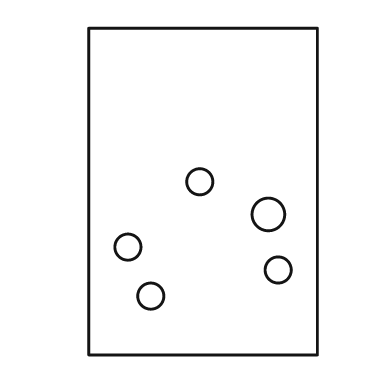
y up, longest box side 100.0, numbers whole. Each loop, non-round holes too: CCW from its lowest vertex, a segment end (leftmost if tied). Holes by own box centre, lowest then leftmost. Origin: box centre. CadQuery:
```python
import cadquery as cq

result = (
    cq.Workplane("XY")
    .moveTo(-35.0, -50.0)
    .lineTo(35.0, -50.0)
    .lineTo(35.0, 50.0)
    .lineTo(-35.0, 50.0)
    .close()
    .moveTo(-16.0, -32.0)
    .circle(4.0)
    .moveTo(23.0, -24.0)
    .circle(4.0)
    .moveTo(-23.0, -17.0)
    .circle(4.0)
    .moveTo(20.0, -7.0)
    .circle(5.0)
    .moveTo(-1.0, 3.0)
    .circle(4.0)
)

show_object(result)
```